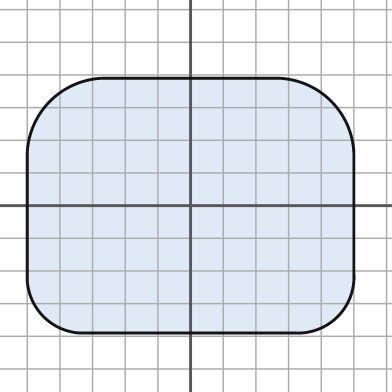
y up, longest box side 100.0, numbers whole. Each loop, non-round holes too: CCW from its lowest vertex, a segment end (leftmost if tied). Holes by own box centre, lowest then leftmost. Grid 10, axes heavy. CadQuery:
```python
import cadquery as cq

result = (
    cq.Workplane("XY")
    .moveTo(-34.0, -39.0)
    .lineTo(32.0, -39.0)
    .threePointArc((45.0, -34.0), (50.0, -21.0))
    .lineTo(50.0, 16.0)
    .threePointArc((43.0, 32.0), (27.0, 39.0))
    .lineTo(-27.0, 39.0)
    .threePointArc((-43.0, 32.0), (-50.0, 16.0))
    .lineTo(-50.0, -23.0)
    .threePointArc((-45.0, -34.0), (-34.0, -39.0))
    .close()
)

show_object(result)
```